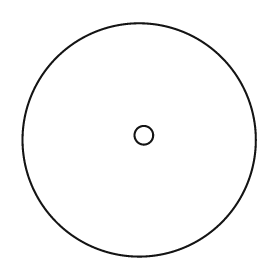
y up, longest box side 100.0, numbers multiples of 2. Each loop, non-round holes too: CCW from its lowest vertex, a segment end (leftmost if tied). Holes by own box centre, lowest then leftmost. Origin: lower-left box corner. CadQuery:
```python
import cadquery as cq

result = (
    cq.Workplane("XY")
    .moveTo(50.0, 50.0)
    .circle(50.0)
    .moveTo(52.0, 52.0)
    .circle(4.0)
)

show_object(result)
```